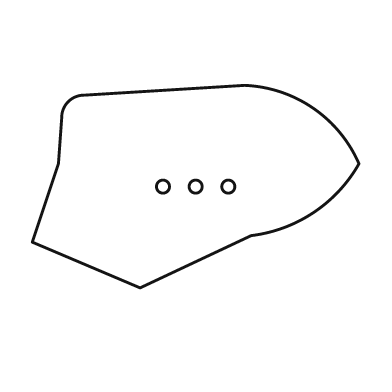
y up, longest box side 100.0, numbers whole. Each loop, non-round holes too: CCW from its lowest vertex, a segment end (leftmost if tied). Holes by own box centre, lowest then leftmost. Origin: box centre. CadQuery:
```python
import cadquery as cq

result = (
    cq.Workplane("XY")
    .moveTo(-17.0, -31.0)
    .lineTo(17.0, -15.0)
    .threePointArc((36.0, -8.0), (50.0, 7.0))
    .threePointArc((36.0, 24.0), (15.0, 31.0))
    .lineTo(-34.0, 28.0)
    .threePointArc((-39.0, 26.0), (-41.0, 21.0))
    .lineTo(-42.0, 7.0)
    .lineTo(-50.0, -17.0)
    .close()
    .moveTo(-10.0, 0.0)
    .circle(2.0)
    .moveTo(0.0, 0.0)
    .circle(2.0)
    .moveTo(10.0, 0.0)
    .circle(2.0)
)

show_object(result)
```